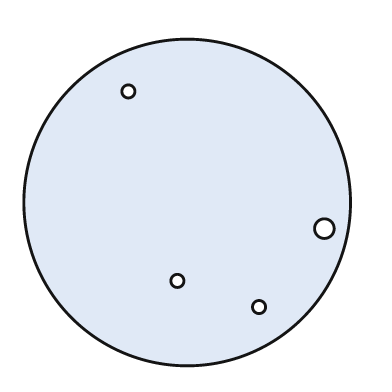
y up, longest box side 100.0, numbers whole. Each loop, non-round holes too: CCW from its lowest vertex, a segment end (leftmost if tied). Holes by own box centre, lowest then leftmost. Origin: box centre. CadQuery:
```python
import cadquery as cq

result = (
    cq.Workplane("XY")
    .moveTo(0.0, 0.0)
    .circle(50.0)
    .moveTo(22.0, -32.0)
    .circle(2.0)
    .moveTo(-3.0, -24.0)
    .circle(2.0)
    .moveTo(42.0, -8.0)
    .circle(3.0)
    .moveTo(-18.0, 34.0)
    .circle(2.0)
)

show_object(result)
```